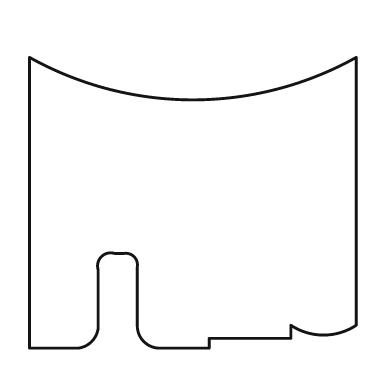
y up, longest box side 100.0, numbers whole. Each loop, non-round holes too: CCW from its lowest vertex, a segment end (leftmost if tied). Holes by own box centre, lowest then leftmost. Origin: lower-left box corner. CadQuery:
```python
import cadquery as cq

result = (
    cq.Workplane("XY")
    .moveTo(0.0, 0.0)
    .lineTo(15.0, 0.0)
    .threePointArc((19.0, 2.0), (21.0, 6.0))
    .lineTo(21.0, 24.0)
    .threePointArc((22.0, 28.0), (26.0, 29.0))
    .lineTo(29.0, 29.0)
    .threePointArc((32.0, 28.0), (33.0, 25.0))
    .lineTo(33.0, 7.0)
    .threePointArc((35.0, 2.0), (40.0, 0.0))
    .lineTo(55.0, 0.0)
    .lineTo(55.0, 3.0)
    .lineTo(80.0, 3.0)
    .lineTo(80.0, 7.0)
    .threePointArc((90.0, 4.0), (100.0, 7.0))
    .lineTo(100.0, 89.0)
    .threePointArc((50.0, 76.0), (0.0, 89.0))
    .close()
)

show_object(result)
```